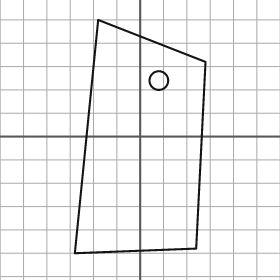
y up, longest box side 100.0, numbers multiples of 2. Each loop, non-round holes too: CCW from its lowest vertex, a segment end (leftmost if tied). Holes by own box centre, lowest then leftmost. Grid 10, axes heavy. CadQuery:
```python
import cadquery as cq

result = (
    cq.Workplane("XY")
    .moveTo(-28.0, -50.0)
    .lineTo(24.0, -48.0)
    .lineTo(28.0, 32.0)
    .lineTo(-18.0, 50.0)
    .close()
    .moveTo(8.0, 24.0)
    .circle(4.0)
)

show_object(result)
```